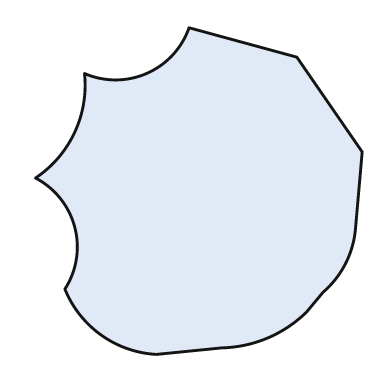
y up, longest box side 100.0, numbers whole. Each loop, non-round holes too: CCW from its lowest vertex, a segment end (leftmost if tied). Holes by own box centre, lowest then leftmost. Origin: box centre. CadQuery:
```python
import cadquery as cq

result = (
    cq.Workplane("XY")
    .moveTo(-13.0, -50.0)
    .lineTo(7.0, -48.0)
    .threePointArc((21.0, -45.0), (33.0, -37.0))
    .lineTo(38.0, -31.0)
    .threePointArc((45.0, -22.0), (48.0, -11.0))
    .lineTo(50.0, 12.0)
    .lineTo(30.0, 41.0)
    .lineTo(-3.0, 50.0)
    .threePointArc((-16.0, 36.0), (-35.0, 36.0))
    .threePointArc((-38.0, 18.0), (-50.0, 4.0))
    .threePointArc((-38.0, -11.0), (-41.0, -30.0))
    .threePointArc((-30.0, -44.0), (-13.0, -50.0))
    .close()
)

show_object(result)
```